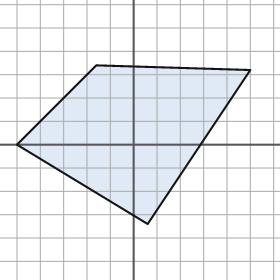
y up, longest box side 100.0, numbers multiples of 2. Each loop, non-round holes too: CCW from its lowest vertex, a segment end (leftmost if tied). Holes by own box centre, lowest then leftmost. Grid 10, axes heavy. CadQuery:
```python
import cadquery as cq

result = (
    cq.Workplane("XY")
    .moveTo(6.0, -34.0)
    .lineTo(50.0, 32.0)
    .lineTo(-16.0, 34.0)
    .lineTo(-50.0, 0.0)
    .close()
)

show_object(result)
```